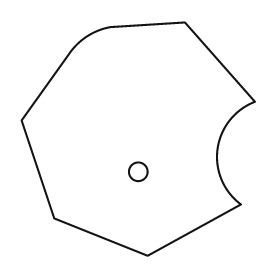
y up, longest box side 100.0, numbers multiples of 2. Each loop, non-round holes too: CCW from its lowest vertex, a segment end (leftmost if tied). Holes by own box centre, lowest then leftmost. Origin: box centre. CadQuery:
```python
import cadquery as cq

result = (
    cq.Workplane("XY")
    .moveTo(4.0, -50.0)
    .lineTo(44.0, -28.0)
    .threePointArc((34.0, -4.0), (50.0, 16.0))
    .lineTo(20.0, 50.0)
    .lineTo(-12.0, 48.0)
    .threePointArc((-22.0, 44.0), (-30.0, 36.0))
    .lineTo(-50.0, 8.0)
    .lineTo(-36.0, -34.0)
    .close()
    .moveTo(0.0, -14.0)
    .circle(4.0)
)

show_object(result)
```